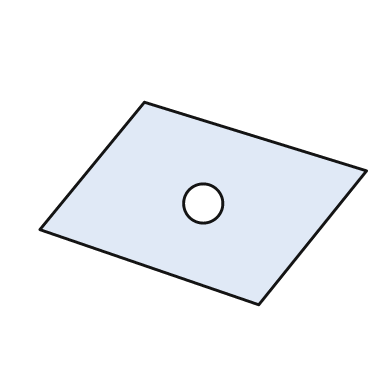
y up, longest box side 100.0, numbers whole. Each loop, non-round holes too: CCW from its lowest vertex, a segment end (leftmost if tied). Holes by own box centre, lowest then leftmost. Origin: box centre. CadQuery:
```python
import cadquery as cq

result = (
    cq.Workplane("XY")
    .moveTo(17.0, -31.0)
    .lineTo(50.0, 10.0)
    .lineTo(-18.0, 31.0)
    .lineTo(-50.0, -8.0)
    .close()
    .moveTo(0.0, 0.0)
    .circle(6.0)
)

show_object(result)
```